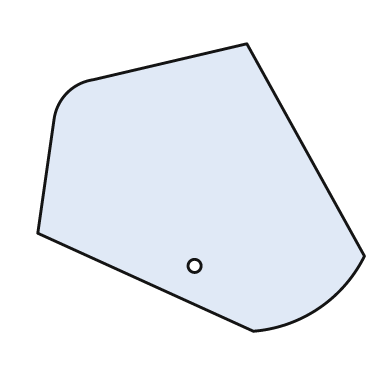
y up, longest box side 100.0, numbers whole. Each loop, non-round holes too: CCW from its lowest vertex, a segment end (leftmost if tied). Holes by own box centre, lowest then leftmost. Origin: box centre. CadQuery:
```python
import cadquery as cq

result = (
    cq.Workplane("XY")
    .moveTo(16.0, -44.0)
    .threePointArc((36.0, -37.0), (50.0, -21.0))
    .lineTo(14.0, 44.0)
    .lineTo(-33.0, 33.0)
    .threePointArc((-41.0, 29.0), (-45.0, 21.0))
    .lineTo(-50.0, -14.0)
    .close()
    .moveTo(-2.0, -24.0)
    .circle(2.0)
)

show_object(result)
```